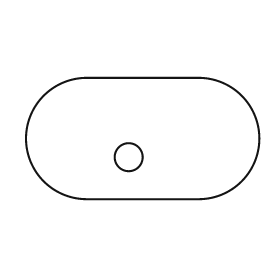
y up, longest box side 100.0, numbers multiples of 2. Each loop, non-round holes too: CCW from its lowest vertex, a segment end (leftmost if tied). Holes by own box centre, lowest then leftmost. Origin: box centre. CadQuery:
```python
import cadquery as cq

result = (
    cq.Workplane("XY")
    .moveTo(-24.0, -26.0)
    .lineTo(24.0, -26.0)
    .threePointArc((50.0, 0.0), (24.0, 26.0))
    .lineTo(-24.0, 26.0)
    .threePointArc((-50.0, 0.0), (-24.0, -26.0))
    .close()
    .moveTo(-6.0, -8.0)
    .circle(6.0)
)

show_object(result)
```